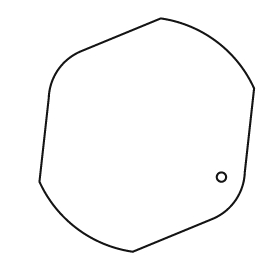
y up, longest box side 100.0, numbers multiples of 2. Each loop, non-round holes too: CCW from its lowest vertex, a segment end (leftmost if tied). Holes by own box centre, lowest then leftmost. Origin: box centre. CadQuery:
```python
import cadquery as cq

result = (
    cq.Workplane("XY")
    .moveTo(-6.0, -50.0)
    .lineTo(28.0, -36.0)
    .threePointArc((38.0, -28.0), (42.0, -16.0))
    .lineTo(46.0, 20.0)
    .threePointArc((30.0, 40.0), (6.0, 50.0))
    .lineTo(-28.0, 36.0)
    .threePointArc((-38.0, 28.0), (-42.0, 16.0))
    .lineTo(-46.0, -20.0)
    .threePointArc((-30.0, -40.0), (-6.0, -50.0))
    .close()
    .moveTo(32.0, -18.0)
    .circle(2.0)
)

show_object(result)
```